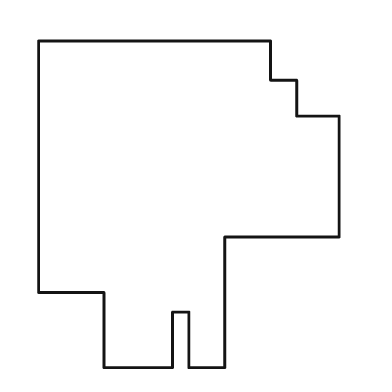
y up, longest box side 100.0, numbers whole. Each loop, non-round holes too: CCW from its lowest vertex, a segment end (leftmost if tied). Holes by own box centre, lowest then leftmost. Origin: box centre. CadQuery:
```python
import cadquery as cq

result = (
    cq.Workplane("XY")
    .moveTo(-26.0, -50.0)
    .lineTo(-5.0, -50.0)
    .lineTo(-5.0, -33.0)
    .lineTo(0.0, -33.0)
    .lineTo(0.0, -50.0)
    .lineTo(11.0, -50.0)
    .lineTo(11.0, -10.0)
    .lineTo(46.0, -10.0)
    .lineTo(46.0, 27.0)
    .lineTo(33.0, 27.0)
    .lineTo(33.0, 38.0)
    .lineTo(25.0, 38.0)
    .lineTo(25.0, 50.0)
    .lineTo(-46.0, 50.0)
    .lineTo(-46.0, -27.0)
    .lineTo(-26.0, -27.0)
    .close()
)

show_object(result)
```